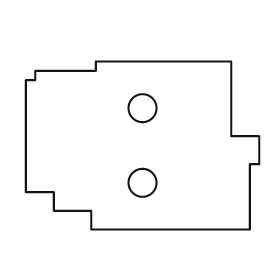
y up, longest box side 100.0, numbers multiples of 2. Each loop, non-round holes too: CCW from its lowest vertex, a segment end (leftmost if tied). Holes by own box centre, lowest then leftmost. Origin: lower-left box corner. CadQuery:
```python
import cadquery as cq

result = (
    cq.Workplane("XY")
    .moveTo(28.0, 0.0)
    .lineTo(96.0, 0.0)
    .lineTo(96.0, 28.0)
    .lineTo(100.0, 28.0)
    .lineTo(100.0, 40.0)
    .lineTo(88.0, 40.0)
    .lineTo(88.0, 72.0)
    .lineTo(30.0, 72.0)
    .lineTo(30.0, 68.0)
    .lineTo(4.0, 68.0)
    .lineTo(4.0, 64.0)
    .lineTo(0.0, 64.0)
    .lineTo(0.0, 16.0)
    .lineTo(12.0, 16.0)
    .lineTo(12.0, 8.0)
    .lineTo(28.0, 8.0)
    .close()
    .moveTo(50.0, 20.0)
    .circle(6.0)
    .moveTo(50.0, 52.0)
    .circle(6.0)
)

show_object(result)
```